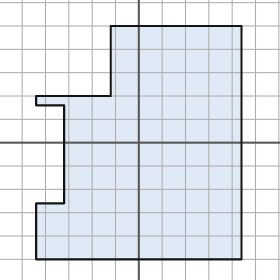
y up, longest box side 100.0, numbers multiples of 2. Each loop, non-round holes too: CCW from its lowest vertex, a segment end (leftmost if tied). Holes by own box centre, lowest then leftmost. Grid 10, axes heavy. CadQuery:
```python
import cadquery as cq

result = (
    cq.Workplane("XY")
    .moveTo(-44.0, -50.0)
    .lineTo(44.0, -50.0)
    .lineTo(44.0, 50.0)
    .lineTo(-12.0, 50.0)
    .lineTo(-12.0, 20.0)
    .lineTo(-44.0, 20.0)
    .lineTo(-44.0, 16.0)
    .lineTo(-32.0, 16.0)
    .lineTo(-32.0, -26.0)
    .lineTo(-44.0, -26.0)
    .close()
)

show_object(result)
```